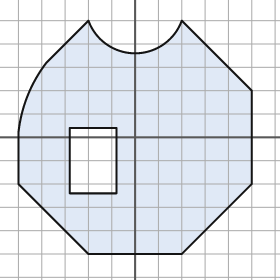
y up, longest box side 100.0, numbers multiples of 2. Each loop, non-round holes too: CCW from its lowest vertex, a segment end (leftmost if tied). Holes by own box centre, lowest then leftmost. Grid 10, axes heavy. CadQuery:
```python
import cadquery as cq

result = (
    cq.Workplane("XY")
    .moveTo(-20.0, -50.0)
    .lineTo(20.0, -50.0)
    .lineTo(50.0, -20.0)
    .lineTo(50.0, 20.0)
    .lineTo(20.0, 50.0)
    .threePointArc((0.0, 36.0), (-20.0, 50.0))
    .lineTo(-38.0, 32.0)
    .threePointArc((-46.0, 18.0), (-50.0, 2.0))
    .lineTo(-50.0, -20.0)
    .close()
    .moveTo(-28.0, -24.0)
    .lineTo(-8.0, -24.0)
    .lineTo(-8.0, 4.0)
    .lineTo(-28.0, 4.0)
    .close()
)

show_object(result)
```